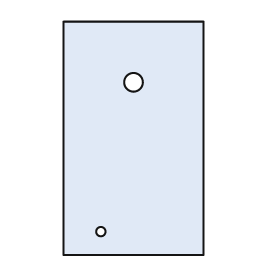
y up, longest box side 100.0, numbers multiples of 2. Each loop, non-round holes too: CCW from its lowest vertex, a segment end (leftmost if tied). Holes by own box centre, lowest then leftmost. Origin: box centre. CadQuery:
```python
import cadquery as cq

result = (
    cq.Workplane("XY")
    .moveTo(-30.0, -50.0)
    .lineTo(30.0, -50.0)
    .lineTo(30.0, 50.0)
    .lineTo(-30.0, 50.0)
    .close()
    .moveTo(-14.0, -40.0)
    .circle(2.0)
    .moveTo(0.0, 24.0)
    .circle(4.0)
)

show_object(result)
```